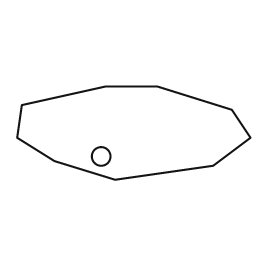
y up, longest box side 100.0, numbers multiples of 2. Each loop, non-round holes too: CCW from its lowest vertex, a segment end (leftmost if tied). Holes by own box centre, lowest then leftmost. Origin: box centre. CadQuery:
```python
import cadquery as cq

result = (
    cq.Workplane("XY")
    .moveTo(-8.0, -20.0)
    .lineTo(34.0, -14.0)
    .lineTo(50.0, -2.0)
    .lineTo(42.0, 10.0)
    .lineTo(10.0, 20.0)
    .lineTo(-12.0, 20.0)
    .lineTo(-48.0, 12.0)
    .lineTo(-50.0, -2.0)
    .lineTo(-34.0, -12.0)
    .close()
    .moveTo(-14.0, -10.0)
    .circle(4.0)
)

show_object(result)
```